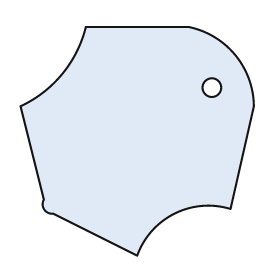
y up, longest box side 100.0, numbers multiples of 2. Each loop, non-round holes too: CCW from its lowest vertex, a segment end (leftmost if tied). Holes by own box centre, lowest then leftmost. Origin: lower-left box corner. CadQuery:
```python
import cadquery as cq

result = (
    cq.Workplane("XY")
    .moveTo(50.0, 0.0)
    .threePointArc((66.0, 18.0), (90.0, 20.0))
    .lineTo(100.0, 64.0)
    .threePointArc((92.0, 86.0), (72.0, 98.0))
    .lineTo(28.0, 98.0)
    .threePointArc((18.0, 78.0), (0.0, 64.0))
    .lineTo(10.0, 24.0)
    .threePointArc((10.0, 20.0), (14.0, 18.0))
    .close()
    .moveTo(82.0, 72.0)
    .circle(4.0)
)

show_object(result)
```